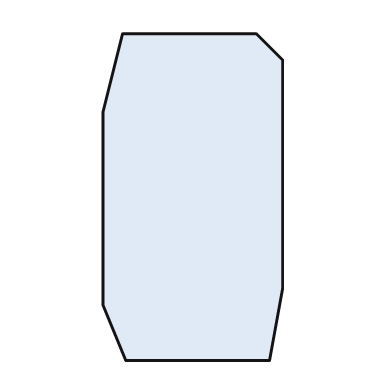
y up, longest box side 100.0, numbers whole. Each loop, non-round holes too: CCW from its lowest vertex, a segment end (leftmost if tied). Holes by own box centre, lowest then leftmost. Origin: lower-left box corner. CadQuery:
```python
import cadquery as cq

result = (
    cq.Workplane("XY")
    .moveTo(7.0, 0.0)
    .lineTo(51.0, 0.0)
    .lineTo(55.0, 22.0)
    .lineTo(55.0, 92.0)
    .lineTo(47.0, 100.0)
    .lineTo(6.0, 100.0)
    .lineTo(0.0, 76.0)
    .lineTo(0.0, 17.0)
    .close()
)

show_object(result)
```